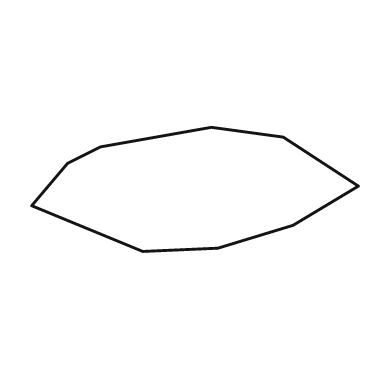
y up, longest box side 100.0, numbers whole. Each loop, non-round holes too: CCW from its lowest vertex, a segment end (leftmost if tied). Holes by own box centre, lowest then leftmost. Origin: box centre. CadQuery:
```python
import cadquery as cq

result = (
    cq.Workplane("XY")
    .moveTo(-16.0, -19.0)
    .lineTo(7.0, -18.0)
    .lineTo(30.0, -11.0)
    .lineTo(50.0, 1.0)
    .lineTo(27.0, 16.0)
    .lineTo(5.0, 19.0)
    .lineTo(-29.0, 13.0)
    .lineTo(-39.0, 8.0)
    .lineTo(-50.0, -5.0)
    .close()
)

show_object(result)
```